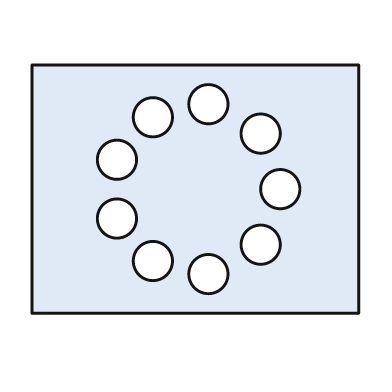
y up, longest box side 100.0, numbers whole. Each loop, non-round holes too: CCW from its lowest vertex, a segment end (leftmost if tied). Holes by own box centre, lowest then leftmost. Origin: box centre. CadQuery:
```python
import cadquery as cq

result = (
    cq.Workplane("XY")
    .moveTo(-50.0, -38.0)
    .lineTo(50.0, -38.0)
    .lineTo(50.0, 38.0)
    .lineTo(-50.0, 38.0)
    .close()
    .moveTo(4.0, -26.0)
    .circle(6.0)
    .moveTo(-13.0, -22.0)
    .circle(6.0)
    .moveTo(20.0, -17.0)
    .circle(6.0)
    .moveTo(-24.0, -9.0)
    .circle(6.0)
    .moveTo(26.0, 0.0)
    .circle(6.0)
    .moveTo(-24.0, 9.0)
    .circle(6.0)
    .moveTo(20.0, 17.0)
    .circle(6.0)
    .moveTo(-13.0, 22.0)
    .circle(6.0)
    .moveTo(4.0, 26.0)
    .circle(6.0)
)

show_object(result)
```